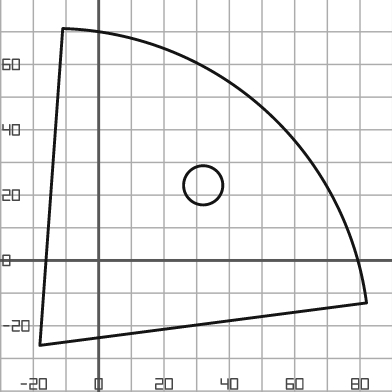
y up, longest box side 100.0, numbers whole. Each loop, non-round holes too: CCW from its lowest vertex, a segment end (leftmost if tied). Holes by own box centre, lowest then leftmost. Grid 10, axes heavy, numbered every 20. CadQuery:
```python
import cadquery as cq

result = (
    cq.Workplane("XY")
    .moveTo(-18.0, -26.0)
    .lineTo(82.0, -13.0)
    .threePointArc((51.0, 46.0), (-11.0, 71.0))
    .close()
    .moveTo(32.0, 23.0)
    .circle(6.0)
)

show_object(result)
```